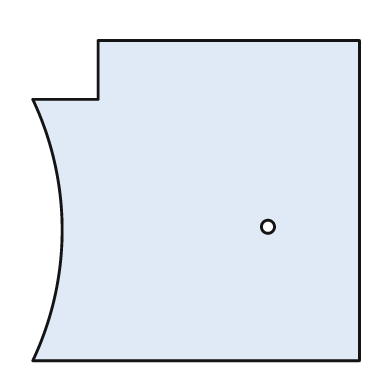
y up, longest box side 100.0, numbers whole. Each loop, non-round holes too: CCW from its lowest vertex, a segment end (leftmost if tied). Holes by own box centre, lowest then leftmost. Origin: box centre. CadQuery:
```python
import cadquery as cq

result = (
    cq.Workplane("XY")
    .moveTo(-50.0, -49.0)
    .lineTo(50.0, -49.0)
    .lineTo(50.0, 49.0)
    .lineTo(-30.0, 49.0)
    .lineTo(-30.0, 31.0)
    .lineTo(-50.0, 31.0)
    .threePointArc((-41.0, -9.0), (-50.0, -49.0))
    .close()
    .moveTo(22.0, -8.0)
    .circle(2.0)
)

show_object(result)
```